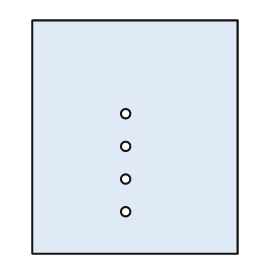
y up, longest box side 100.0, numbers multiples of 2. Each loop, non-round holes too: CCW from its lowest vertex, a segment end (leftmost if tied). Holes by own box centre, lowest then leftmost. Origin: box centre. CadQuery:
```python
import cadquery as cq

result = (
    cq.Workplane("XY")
    .moveTo(-44.0, -50.0)
    .lineTo(44.0, -50.0)
    .lineTo(44.0, 50.0)
    .lineTo(-44.0, 50.0)
    .close()
    .moveTo(-4.0, -32.0)
    .circle(2.0)
    .moveTo(-4.0, -18.0)
    .circle(2.0)
    .moveTo(-4.0, -4.0)
    .circle(2.0)
    .moveTo(-4.0, 10.0)
    .circle(2.0)
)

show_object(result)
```